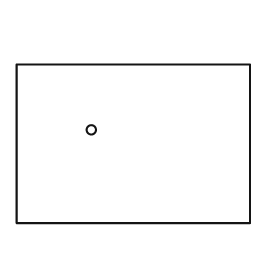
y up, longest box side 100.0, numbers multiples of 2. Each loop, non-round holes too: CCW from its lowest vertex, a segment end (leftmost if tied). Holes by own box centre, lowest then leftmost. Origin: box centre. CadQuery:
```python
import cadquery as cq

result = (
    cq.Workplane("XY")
    .moveTo(-50.0, -34.0)
    .lineTo(50.0, -34.0)
    .lineTo(50.0, 34.0)
    .lineTo(-50.0, 34.0)
    .close()
    .moveTo(-18.0, 6.0)
    .circle(2.0)
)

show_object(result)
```